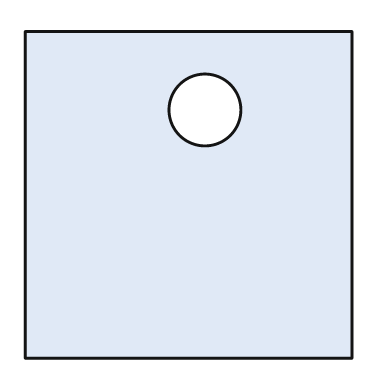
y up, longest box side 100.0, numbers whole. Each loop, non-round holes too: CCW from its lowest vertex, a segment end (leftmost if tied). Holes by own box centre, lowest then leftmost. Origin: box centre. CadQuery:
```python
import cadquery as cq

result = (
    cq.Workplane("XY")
    .moveTo(-50.0, -50.0)
    .lineTo(50.0, -50.0)
    .lineTo(50.0, 50.0)
    .lineTo(-50.0, 50.0)
    .close()
    .moveTo(5.0, 26.0)
    .circle(11.0)
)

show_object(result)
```